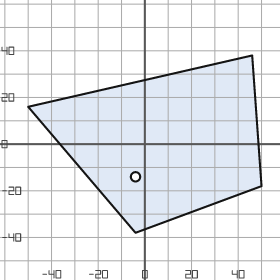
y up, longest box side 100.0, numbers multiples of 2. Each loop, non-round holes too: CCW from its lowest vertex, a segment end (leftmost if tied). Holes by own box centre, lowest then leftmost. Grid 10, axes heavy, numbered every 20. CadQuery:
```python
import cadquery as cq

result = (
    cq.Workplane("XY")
    .moveTo(-4.0, -38.0)
    .lineTo(50.0, -18.0)
    .lineTo(46.0, 38.0)
    .lineTo(-50.0, 16.0)
    .close()
    .moveTo(-4.0, -14.0)
    .circle(2.0)
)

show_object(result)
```